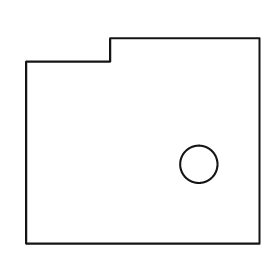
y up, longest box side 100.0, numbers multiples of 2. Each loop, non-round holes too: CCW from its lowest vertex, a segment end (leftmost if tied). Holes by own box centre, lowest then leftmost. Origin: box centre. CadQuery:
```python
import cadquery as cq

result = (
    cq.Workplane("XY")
    .moveTo(-50.0, -44.0)
    .lineTo(50.0, -44.0)
    .lineTo(50.0, 44.0)
    .lineTo(-14.0, 44.0)
    .lineTo(-14.0, 34.0)
    .lineTo(-50.0, 34.0)
    .close()
    .moveTo(24.0, -10.0)
    .circle(8.0)
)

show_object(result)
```